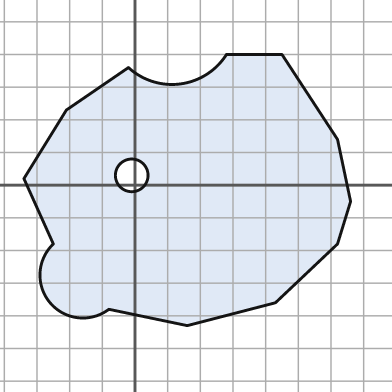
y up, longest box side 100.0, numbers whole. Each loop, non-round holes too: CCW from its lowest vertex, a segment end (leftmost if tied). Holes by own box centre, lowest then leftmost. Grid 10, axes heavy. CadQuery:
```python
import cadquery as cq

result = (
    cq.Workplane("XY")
    .moveTo(16.0, -43.0)
    .lineTo(43.0, -36.0)
    .lineTo(62.0, -18.0)
    .lineTo(66.0, -5.0)
    .lineTo(62.0, 14.0)
    .lineTo(45.0, 40.0)
    .lineTo(28.0, 40.0)
    .threePointArc((14.0, 31.0), (-2.0, 36.0))
    .lineTo(-21.0, 23.0)
    .lineTo(-34.0, 2.0)
    .lineTo(-25.0, -18.0)
    .threePointArc((-26.0, -36.0), (-8.0, -38.0))
    .close()
    .moveTo(-1.0, 3.0)
    .circle(5.0)
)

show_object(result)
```